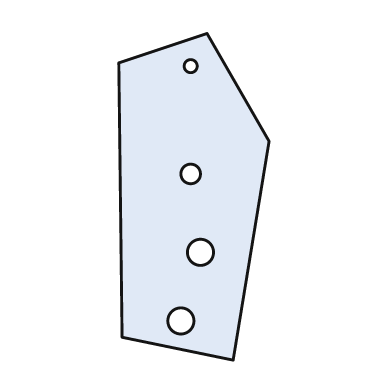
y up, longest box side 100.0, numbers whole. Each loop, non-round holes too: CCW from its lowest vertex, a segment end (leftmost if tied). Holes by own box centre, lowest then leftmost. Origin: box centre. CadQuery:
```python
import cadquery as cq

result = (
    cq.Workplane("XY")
    .moveTo(12.0, -50.0)
    .lineTo(23.0, 17.0)
    .lineTo(4.0, 50.0)
    .lineTo(-23.0, 41.0)
    .lineTo(-22.0, -43.0)
    .close()
    .moveTo(-4.0, -38.0)
    .circle(4.0)
    .moveTo(2.0, -17.0)
    .circle(4.0)
    .moveTo(-1.0, 7.0)
    .circle(3.0)
    .moveTo(-1.0, 40.0)
    .circle(2.0)
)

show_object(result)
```